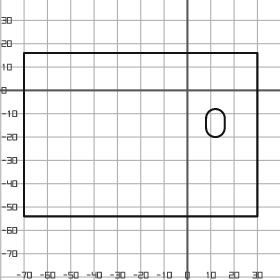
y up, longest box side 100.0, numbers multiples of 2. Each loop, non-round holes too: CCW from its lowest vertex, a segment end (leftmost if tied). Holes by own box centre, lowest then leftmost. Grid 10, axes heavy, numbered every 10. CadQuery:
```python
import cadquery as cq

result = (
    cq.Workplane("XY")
    .moveTo(-70.0, -54.0)
    .lineTo(30.0, -54.0)
    .lineTo(30.0, 16.0)
    .lineTo(-70.0, 16.0)
    .close()
    .moveTo(8.0, -16.0)
    .threePointArc((12.0, -20.0), (16.0, -16.0))
    .lineTo(16.0, -12.0)
    .threePointArc((12.0, -8.0), (8.0, -12.0))
    .close()
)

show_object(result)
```